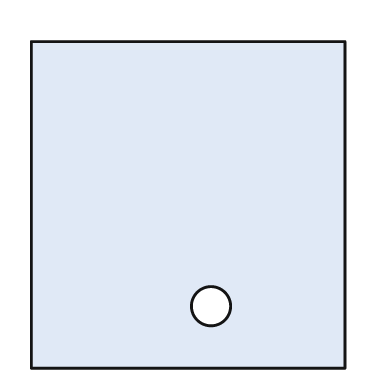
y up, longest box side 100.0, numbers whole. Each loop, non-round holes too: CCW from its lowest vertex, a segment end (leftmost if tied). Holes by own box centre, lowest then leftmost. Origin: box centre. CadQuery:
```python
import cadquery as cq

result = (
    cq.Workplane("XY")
    .moveTo(-48.0, -50.0)
    .lineTo(48.0, -50.0)
    .lineTo(48.0, 50.0)
    .lineTo(-48.0, 50.0)
    .close()
    .moveTo(7.0, -31.0)
    .circle(6.0)
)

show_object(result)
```